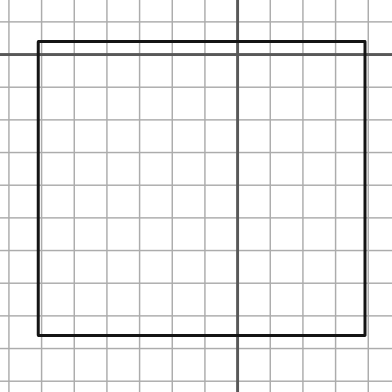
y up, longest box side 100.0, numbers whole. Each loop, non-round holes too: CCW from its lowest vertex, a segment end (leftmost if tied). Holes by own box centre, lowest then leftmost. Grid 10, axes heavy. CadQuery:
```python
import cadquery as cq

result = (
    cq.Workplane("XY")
    .moveTo(-61.0, -86.0)
    .lineTo(39.0, -86.0)
    .lineTo(39.0, 4.0)
    .lineTo(-61.0, 4.0)
    .close()
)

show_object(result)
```